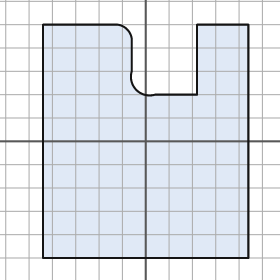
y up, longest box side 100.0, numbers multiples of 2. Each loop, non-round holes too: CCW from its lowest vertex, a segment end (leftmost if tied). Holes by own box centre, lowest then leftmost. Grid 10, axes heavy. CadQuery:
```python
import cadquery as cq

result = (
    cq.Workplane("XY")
    .moveTo(-44.0, -50.0)
    .lineTo(44.0, -50.0)
    .lineTo(44.0, 50.0)
    .lineTo(22.0, 50.0)
    .lineTo(22.0, 20.0)
    .lineTo(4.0, 20.0)
    .threePointArc((-4.0, 22.0), (-6.0, 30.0))
    .lineTo(-6.0, 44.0)
    .threePointArc((-8.0, 48.0), (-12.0, 50.0))
    .lineTo(-44.0, 50.0)
    .close()
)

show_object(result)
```